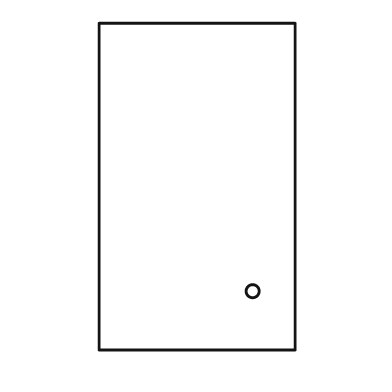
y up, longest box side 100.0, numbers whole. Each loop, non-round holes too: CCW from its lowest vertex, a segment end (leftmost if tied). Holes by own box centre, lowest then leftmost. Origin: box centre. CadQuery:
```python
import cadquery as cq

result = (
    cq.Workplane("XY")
    .moveTo(-30.0, -50.0)
    .lineTo(30.0, -50.0)
    .lineTo(30.0, 50.0)
    .lineTo(-30.0, 50.0)
    .close()
    .moveTo(17.0, -32.0)
    .circle(2.0)
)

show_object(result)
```